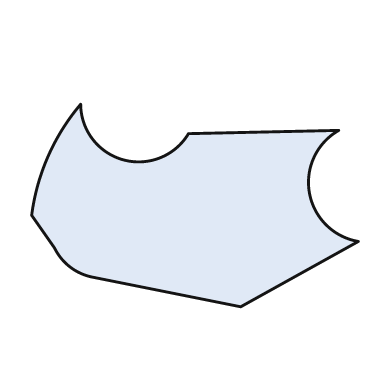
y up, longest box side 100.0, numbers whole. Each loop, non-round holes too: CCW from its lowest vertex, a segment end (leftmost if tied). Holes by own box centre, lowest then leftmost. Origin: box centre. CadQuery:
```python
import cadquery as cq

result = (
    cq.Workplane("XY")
    .moveTo(14.0, -31.0)
    .lineTo(50.0, -11.0)
    .threePointArc((35.0, 4.0), (44.0, 23.0))
    .lineTo(-2.0, 22.0)
    .threePointArc((-22.0, 14.0), (-35.0, 31.0))
    .threePointArc((-45.0, 15.0), (-50.0, -3.0))
    .lineTo(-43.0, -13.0)
    .threePointArc((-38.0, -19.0), (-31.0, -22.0))
    .close()
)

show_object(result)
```